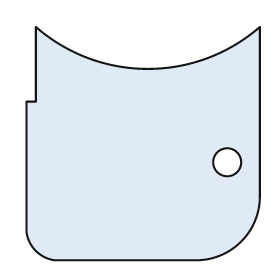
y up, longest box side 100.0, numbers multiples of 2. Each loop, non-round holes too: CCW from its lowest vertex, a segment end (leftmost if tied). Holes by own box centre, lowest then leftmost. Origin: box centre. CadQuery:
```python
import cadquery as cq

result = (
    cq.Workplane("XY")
    .moveTo(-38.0, -50.0)
    .lineTo(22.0, -50.0)
    .threePointArc((42.0, -42.0), (50.0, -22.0))
    .lineTo(50.0, 50.0)
    .threePointArc((2.0, 32.0), (-46.0, 50.0))
    .lineTo(-46.0, 18.0)
    .lineTo(-50.0, 18.0)
    .lineTo(-50.0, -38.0)
    .threePointArc((-46.0, -46.0), (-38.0, -50.0))
    .close()
    .moveTo(36.0, -8.0)
    .circle(6.0)
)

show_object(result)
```